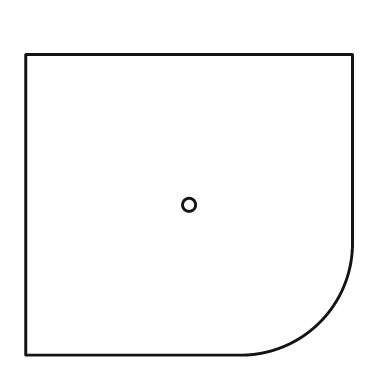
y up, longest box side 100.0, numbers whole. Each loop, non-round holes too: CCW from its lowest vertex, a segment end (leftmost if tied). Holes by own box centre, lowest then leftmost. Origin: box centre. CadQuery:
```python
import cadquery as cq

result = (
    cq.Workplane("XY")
    .moveTo(-50.0, -46.0)
    .lineTo(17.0, -46.0)
    .threePointArc((40.0, -36.0), (50.0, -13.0))
    .lineTo(50.0, 46.0)
    .lineTo(-50.0, 46.0)
    .close()
    .moveTo(0.0, 0.0)
    .circle(2.0)
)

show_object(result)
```